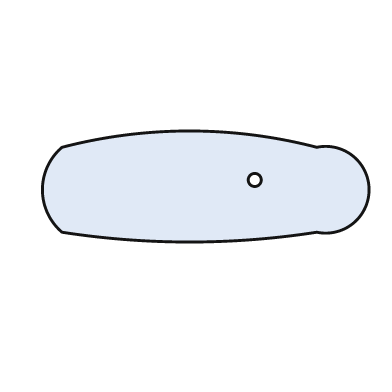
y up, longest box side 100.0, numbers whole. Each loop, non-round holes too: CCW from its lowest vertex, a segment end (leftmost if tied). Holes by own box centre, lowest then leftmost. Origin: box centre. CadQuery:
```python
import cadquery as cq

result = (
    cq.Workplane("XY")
    .moveTo(-44.0, -14.0)
    .threePointArc((-5.0, -17.0), (34.0, -14.0))
    .threePointArc((50.0, -1.0), (34.0, 12.0))
    .threePointArc((-5.0, 17.0), (-44.0, 12.0))
    .threePointArc((-50.0, -1.0), (-44.0, -14.0))
    .close()
    .moveTo(15.0, 2.0)
    .circle(2.0)
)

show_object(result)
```